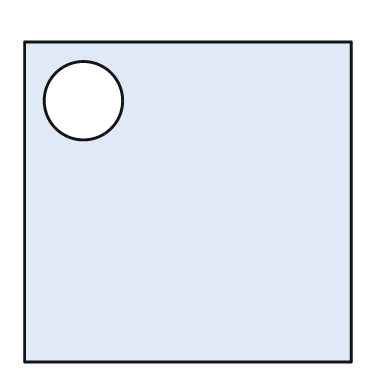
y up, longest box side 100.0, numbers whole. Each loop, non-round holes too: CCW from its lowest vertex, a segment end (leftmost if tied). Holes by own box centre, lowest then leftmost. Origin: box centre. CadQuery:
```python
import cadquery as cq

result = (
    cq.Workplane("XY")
    .moveTo(-50.0, -49.0)
    .lineTo(50.0, -49.0)
    .lineTo(50.0, 49.0)
    .lineTo(-50.0, 49.0)
    .close()
    .moveTo(-32.0, 31.0)
    .circle(12.0)
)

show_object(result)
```